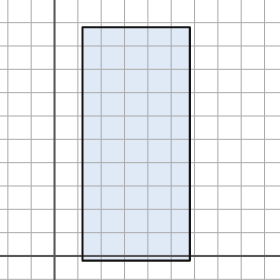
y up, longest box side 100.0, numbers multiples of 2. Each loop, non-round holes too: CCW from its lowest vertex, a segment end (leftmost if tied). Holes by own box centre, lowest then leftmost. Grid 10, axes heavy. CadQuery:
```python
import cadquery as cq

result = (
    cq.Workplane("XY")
    .moveTo(12.0, -2.0)
    .lineTo(58.0, -2.0)
    .lineTo(58.0, 98.0)
    .lineTo(12.0, 98.0)
    .close()
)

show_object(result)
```